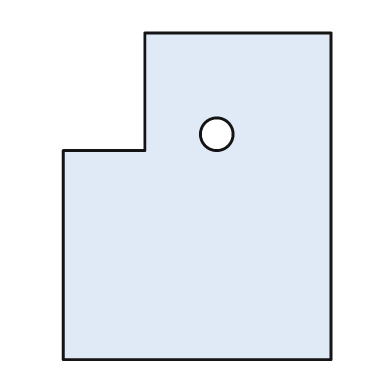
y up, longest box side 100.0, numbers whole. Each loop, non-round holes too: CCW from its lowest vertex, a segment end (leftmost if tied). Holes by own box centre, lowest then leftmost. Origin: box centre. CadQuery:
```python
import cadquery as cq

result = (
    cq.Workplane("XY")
    .moveTo(-41.0, -50.0)
    .lineTo(41.0, -50.0)
    .lineTo(41.0, 50.0)
    .lineTo(-16.0, 50.0)
    .lineTo(-16.0, 14.0)
    .lineTo(-41.0, 14.0)
    .close()
    .moveTo(6.0, 19.0)
    .circle(5.0)
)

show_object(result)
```